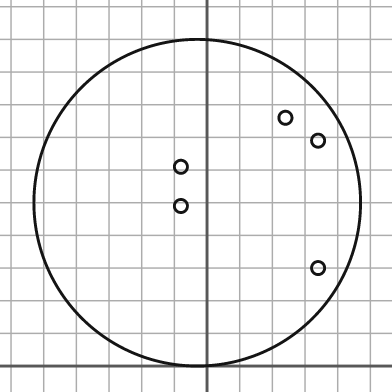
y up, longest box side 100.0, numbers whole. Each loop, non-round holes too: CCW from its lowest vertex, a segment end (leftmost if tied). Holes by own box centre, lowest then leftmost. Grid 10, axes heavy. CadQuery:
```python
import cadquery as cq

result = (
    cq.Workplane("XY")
    .moveTo(-3.0, 50.0)
    .circle(50.0)
    .moveTo(34.0, 30.0)
    .circle(2.0)
    .moveTo(-8.0, 49.0)
    .circle(2.0)
    .moveTo(-8.0, 61.0)
    .circle(2.0)
    .moveTo(34.0, 69.0)
    .circle(2.0)
    .moveTo(24.0, 76.0)
    .circle(2.0)
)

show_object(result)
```